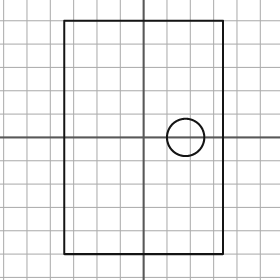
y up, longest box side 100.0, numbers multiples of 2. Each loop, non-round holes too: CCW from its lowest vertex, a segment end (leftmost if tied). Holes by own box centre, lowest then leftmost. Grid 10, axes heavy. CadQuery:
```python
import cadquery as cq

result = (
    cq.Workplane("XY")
    .moveTo(-34.0, -50.0)
    .lineTo(34.0, -50.0)
    .lineTo(34.0, 50.0)
    .lineTo(-34.0, 50.0)
    .close()
    .moveTo(18.0, 0.0)
    .circle(8.0)
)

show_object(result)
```